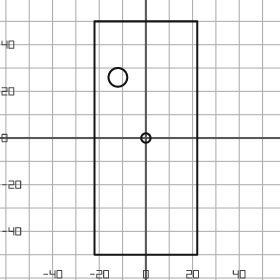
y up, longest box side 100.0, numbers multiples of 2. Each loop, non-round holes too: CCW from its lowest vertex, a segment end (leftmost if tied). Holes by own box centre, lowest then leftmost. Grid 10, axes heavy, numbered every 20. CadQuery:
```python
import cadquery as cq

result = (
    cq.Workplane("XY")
    .moveTo(-22.0, -50.0)
    .lineTo(22.0, -50.0)
    .lineTo(22.0, 50.0)
    .lineTo(-22.0, 50.0)
    .close()
    .moveTo(0.0, 0.0)
    .circle(2.0)
    .moveTo(-12.0, 26.0)
    .circle(4.0)
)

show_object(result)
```